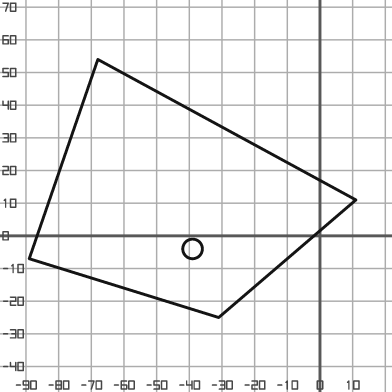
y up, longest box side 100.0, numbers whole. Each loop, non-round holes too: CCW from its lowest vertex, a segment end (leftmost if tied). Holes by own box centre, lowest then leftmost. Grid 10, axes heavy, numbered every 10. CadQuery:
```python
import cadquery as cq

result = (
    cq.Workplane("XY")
    .moveTo(-31.0, -25.0)
    .lineTo(11.0, 11.0)
    .lineTo(-68.0, 54.0)
    .lineTo(-89.0, -7.0)
    .close()
    .moveTo(-39.0, -4.0)
    .circle(3.0)
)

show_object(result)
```